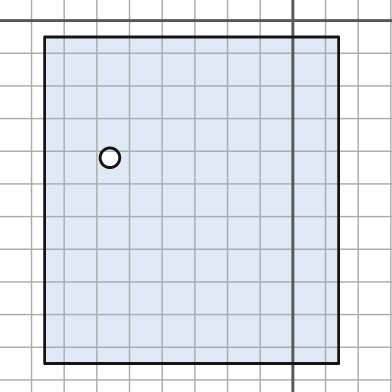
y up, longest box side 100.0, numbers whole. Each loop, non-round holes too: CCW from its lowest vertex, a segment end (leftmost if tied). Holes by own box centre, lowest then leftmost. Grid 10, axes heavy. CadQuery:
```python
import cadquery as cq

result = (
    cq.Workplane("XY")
    .moveTo(-76.0, -105.0)
    .lineTo(14.0, -105.0)
    .lineTo(14.0, -5.0)
    .lineTo(-76.0, -5.0)
    .close()
    .moveTo(-56.0, -42.0)
    .circle(3.0)
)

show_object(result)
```